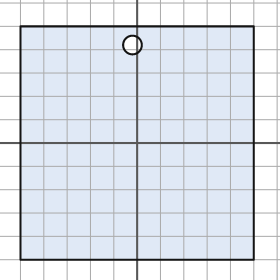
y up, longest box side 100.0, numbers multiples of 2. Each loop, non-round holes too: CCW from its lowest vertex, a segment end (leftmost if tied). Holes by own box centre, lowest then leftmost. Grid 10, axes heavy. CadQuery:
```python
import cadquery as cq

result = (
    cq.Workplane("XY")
    .moveTo(-50.0, -50.0)
    .lineTo(50.0, -50.0)
    .lineTo(50.0, 50.0)
    .lineTo(-50.0, 50.0)
    .close()
    .moveTo(-2.0, 42.0)
    .circle(4.0)
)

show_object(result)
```